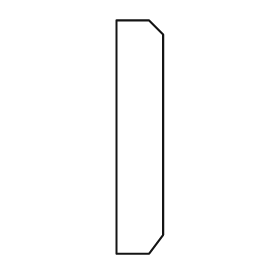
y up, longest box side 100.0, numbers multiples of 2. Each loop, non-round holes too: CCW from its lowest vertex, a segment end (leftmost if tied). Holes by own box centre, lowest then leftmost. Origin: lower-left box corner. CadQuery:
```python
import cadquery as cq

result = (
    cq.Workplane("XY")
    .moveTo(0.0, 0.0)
    .lineTo(14.0, 0.0)
    .lineTo(20.0, 8.0)
    .lineTo(20.0, 94.0)
    .lineTo(14.0, 100.0)
    .lineTo(0.0, 100.0)
    .close()
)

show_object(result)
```